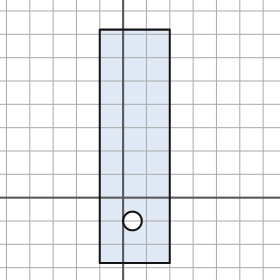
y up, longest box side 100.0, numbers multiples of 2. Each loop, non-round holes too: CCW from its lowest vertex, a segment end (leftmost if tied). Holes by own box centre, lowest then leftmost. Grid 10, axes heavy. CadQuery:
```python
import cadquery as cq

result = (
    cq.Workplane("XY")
    .moveTo(-10.0, -28.0)
    .lineTo(20.0, -28.0)
    .lineTo(20.0, 72.0)
    .lineTo(-10.0, 72.0)
    .close()
    .moveTo(4.0, -10.0)
    .circle(4.0)
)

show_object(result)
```